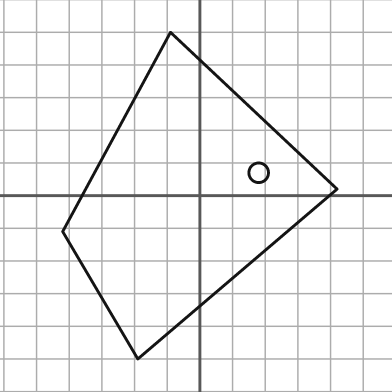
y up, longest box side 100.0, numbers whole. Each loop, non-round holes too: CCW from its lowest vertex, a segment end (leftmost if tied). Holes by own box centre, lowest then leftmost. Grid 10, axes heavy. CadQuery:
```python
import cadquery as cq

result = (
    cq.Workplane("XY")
    .moveTo(-19.0, -50.0)
    .lineTo(42.0, 2.0)
    .lineTo(-9.0, 50.0)
    .lineTo(-42.0, -11.0)
    .close()
    .moveTo(18.0, 7.0)
    .circle(3.0)
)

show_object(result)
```